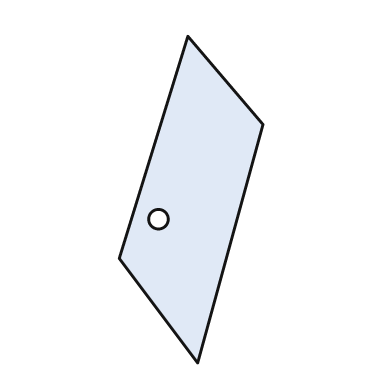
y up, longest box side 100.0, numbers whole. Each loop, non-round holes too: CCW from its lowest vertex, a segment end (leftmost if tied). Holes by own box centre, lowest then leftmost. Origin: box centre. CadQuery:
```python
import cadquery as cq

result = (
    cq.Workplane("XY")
    .moveTo(2.0, -50.0)
    .lineTo(22.0, 23.0)
    .lineTo(-1.0, 50.0)
    .lineTo(-22.0, -18.0)
    .close()
    .moveTo(-10.0, -6.0)
    .circle(3.0)
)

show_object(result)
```